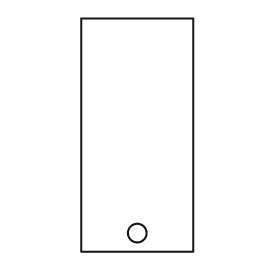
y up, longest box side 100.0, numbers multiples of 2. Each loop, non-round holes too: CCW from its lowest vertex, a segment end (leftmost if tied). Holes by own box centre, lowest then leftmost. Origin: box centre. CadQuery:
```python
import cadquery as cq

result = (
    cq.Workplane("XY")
    .moveTo(-24.0, -50.0)
    .lineTo(24.0, -50.0)
    .lineTo(24.0, 50.0)
    .lineTo(-24.0, 50.0)
    .close()
    .moveTo(0.0, -42.0)
    .circle(4.0)
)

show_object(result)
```